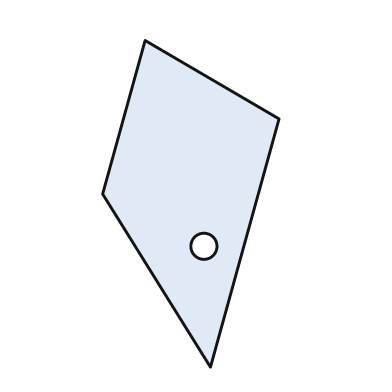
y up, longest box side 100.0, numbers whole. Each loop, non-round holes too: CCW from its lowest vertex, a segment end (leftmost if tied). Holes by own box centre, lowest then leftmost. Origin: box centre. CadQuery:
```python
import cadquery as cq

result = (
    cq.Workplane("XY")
    .moveTo(6.0, -50.0)
    .lineTo(27.0, 26.0)
    .lineTo(-14.0, 50.0)
    .lineTo(-27.0, 3.0)
    .close()
    .moveTo(4.0, -13.0)
    .circle(4.0)
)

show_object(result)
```